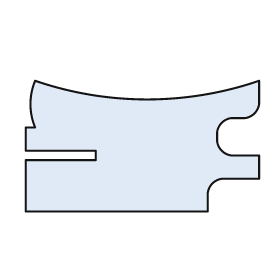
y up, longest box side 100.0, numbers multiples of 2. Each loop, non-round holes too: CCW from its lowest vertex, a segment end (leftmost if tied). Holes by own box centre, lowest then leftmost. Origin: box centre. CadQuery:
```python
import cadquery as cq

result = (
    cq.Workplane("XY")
    .moveTo(-50.0, -28.0)
    .lineTo(28.0, -28.0)
    .lineTo(28.0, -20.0)
    .threePointArc((30.0, -16.0), (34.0, -14.0))
    .lineTo(50.0, -14.0)
    .lineTo(50.0, -4.0)
    .lineTo(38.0, -4.0)
    .threePointArc((34.0, -2.0), (32.0, 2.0))
    .lineTo(32.0, 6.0)
    .threePointArc((34.0, 10.0), (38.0, 12.0))
    .lineTo(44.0, 12.0)
    .threePointArc((48.0, 14.0), (50.0, 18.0))
    .lineTo(50.0, 28.0)
    .threePointArc((2.0, 20.0), (-46.0, 28.0))
    .threePointArc((-48.0, 18.0), (-46.0, 8.0))
    .lineTo(-50.0, 8.0)
    .lineTo(-50.0, -2.0)
    .lineTo(-20.0, -2.0)
    .lineTo(-20.0, -6.0)
    .lineTo(-50.0, -6.0)
    .close()
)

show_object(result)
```